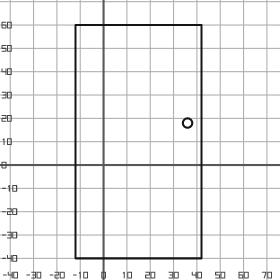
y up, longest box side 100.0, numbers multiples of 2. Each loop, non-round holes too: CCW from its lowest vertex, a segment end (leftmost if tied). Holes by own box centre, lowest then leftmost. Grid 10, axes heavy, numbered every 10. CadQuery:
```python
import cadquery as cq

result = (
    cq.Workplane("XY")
    .moveTo(-12.0, -40.0)
    .lineTo(42.0, -40.0)
    .lineTo(42.0, 60.0)
    .lineTo(-12.0, 60.0)
    .close()
    .moveTo(36.0, 18.0)
    .circle(2.0)
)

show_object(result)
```